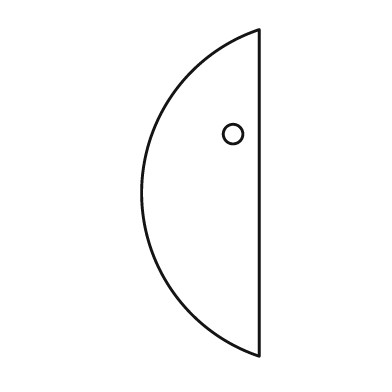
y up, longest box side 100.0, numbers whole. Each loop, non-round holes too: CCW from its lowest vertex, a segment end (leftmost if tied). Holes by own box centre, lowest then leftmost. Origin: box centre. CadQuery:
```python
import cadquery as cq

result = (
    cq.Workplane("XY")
    .moveTo(18.0, -50.0)
    .lineTo(18.0, 50.0)
    .threePointArc((-18.0, 0.0), (18.0, -50.0))
    .close()
    .moveTo(10.0, 18.0)
    .circle(3.0)
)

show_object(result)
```